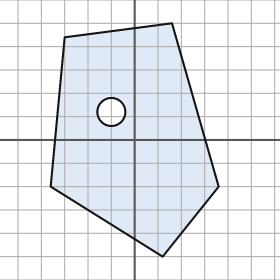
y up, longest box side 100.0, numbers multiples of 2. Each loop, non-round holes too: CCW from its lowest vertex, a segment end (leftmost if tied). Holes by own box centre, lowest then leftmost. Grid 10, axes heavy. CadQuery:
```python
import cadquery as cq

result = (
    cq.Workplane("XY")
    .moveTo(12.0, -50.0)
    .lineTo(36.0, -20.0)
    .lineTo(16.0, 50.0)
    .lineTo(-30.0, 44.0)
    .lineTo(-36.0, -20.0)
    .close()
    .moveTo(-10.0, 12.0)
    .circle(6.0)
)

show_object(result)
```